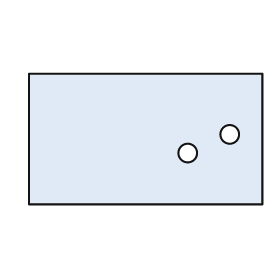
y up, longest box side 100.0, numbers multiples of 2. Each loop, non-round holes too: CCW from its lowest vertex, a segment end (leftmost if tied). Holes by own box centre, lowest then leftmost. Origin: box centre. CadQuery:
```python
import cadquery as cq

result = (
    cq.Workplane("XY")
    .moveTo(-50.0, -28.0)
    .lineTo(50.0, -28.0)
    .lineTo(50.0, 28.0)
    .lineTo(-50.0, 28.0)
    .close()
    .moveTo(18.0, -6.0)
    .circle(4.0)
    .moveTo(36.0, 2.0)
    .circle(4.0)
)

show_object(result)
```